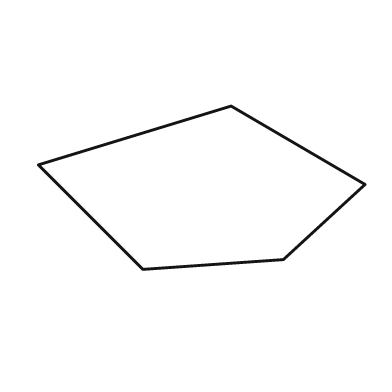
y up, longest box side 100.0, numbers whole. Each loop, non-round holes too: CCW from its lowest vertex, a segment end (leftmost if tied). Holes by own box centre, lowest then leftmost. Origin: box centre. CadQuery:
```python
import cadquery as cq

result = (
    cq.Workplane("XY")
    .moveTo(-18.0, -25.0)
    .lineTo(25.0, -22.0)
    .lineTo(50.0, 1.0)
    .lineTo(9.0, 25.0)
    .lineTo(-50.0, 7.0)
    .close()
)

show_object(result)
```